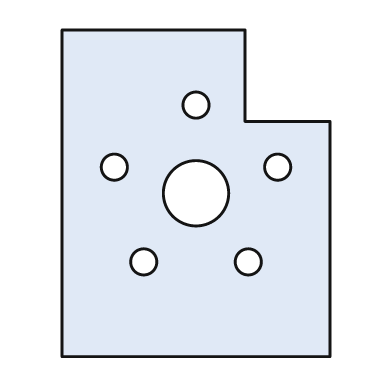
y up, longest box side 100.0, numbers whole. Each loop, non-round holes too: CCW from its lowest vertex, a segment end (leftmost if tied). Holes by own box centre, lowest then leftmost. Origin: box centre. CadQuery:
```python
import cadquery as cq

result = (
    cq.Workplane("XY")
    .moveTo(-41.0, -50.0)
    .lineTo(41.0, -50.0)
    .lineTo(41.0, 22.0)
    .lineTo(15.0, 22.0)
    .lineTo(15.0, 50.0)
    .lineTo(-41.0, 50.0)
    .close()
    .moveTo(-16.0, -21.0)
    .circle(4.0)
    .moveTo(16.0, -21.0)
    .circle(4.0)
    .moveTo(0.0, 0.0)
    .circle(10.0)
    .moveTo(-25.0, 8.0)
    .circle(4.0)
    .moveTo(25.0, 8.0)
    .circle(4.0)
    .moveTo(0.0, 27.0)
    .circle(4.0)
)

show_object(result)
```